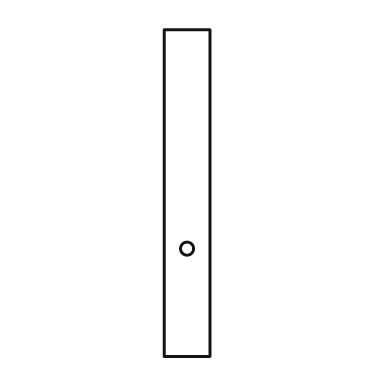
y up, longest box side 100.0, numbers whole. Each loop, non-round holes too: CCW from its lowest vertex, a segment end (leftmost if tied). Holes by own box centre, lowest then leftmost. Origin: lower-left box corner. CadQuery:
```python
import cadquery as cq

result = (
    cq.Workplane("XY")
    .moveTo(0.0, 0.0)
    .lineTo(14.0, 0.0)
    .lineTo(14.0, 100.0)
    .lineTo(0.0, 100.0)
    .close()
    .moveTo(7.0, 33.0)
    .circle(2.0)
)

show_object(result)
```